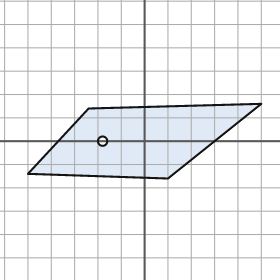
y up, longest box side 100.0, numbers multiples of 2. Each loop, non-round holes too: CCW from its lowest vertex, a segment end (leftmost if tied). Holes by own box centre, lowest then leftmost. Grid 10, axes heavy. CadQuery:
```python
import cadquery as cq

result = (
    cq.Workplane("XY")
    .moveTo(10.0, -16.0)
    .lineTo(50.0, 16.0)
    .lineTo(-24.0, 14.0)
    .lineTo(-50.0, -14.0)
    .close()
    .moveTo(-18.0, 0.0)
    .circle(2.0)
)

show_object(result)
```